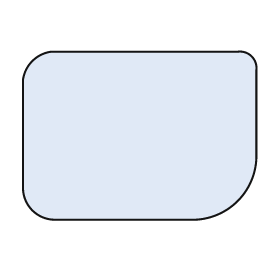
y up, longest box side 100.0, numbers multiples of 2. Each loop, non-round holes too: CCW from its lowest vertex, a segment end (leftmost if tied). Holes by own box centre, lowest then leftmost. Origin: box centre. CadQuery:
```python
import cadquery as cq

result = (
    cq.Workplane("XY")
    .moveTo(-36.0, -36.0)
    .lineTo(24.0, -36.0)
    .threePointArc((42.0, -28.0), (50.0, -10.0))
    .lineTo(50.0, 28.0)
    .threePointArc((48.0, 34.0), (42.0, 36.0))
    .lineTo(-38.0, 36.0)
    .threePointArc((-46.0, 32.0), (-50.0, 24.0))
    .lineTo(-50.0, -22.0)
    .threePointArc((-46.0, -32.0), (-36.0, -36.0))
    .close()
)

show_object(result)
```